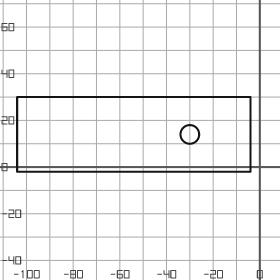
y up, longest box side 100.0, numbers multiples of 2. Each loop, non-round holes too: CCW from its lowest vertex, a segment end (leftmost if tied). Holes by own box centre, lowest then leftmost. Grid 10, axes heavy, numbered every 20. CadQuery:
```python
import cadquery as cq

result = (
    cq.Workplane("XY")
    .moveTo(-104.0, -2.0)
    .lineTo(-4.0, -2.0)
    .lineTo(-4.0, 30.0)
    .lineTo(-104.0, 30.0)
    .close()
    .moveTo(-30.0, 14.0)
    .circle(4.0)
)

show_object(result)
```